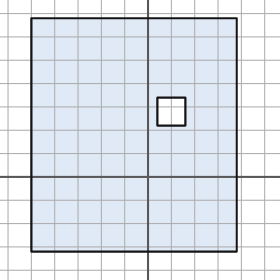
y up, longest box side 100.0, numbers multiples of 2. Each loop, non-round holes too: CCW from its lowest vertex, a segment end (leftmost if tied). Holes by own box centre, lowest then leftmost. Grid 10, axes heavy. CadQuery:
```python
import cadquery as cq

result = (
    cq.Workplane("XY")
    .moveTo(-50.0, -32.0)
    .lineTo(38.0, -32.0)
    .lineTo(38.0, 68.0)
    .lineTo(-50.0, 68.0)
    .close()
    .moveTo(4.0, 22.0)
    .lineTo(16.0, 22.0)
    .lineTo(16.0, 34.0)
    .lineTo(4.0, 34.0)
    .close()
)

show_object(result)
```